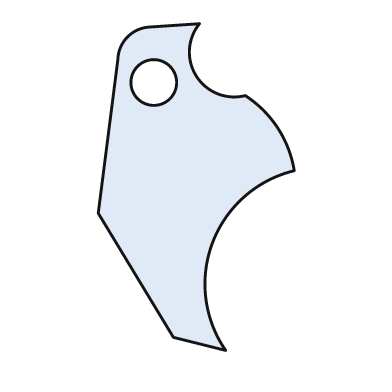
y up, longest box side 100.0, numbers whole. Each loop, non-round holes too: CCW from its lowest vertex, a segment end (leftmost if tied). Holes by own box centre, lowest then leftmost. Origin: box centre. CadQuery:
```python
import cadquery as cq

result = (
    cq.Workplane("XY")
    .moveTo(9.0, -50.0)
    .threePointArc((5.0, -17.0), (30.0, 5.0))
    .threePointArc((25.0, 18.0), (15.0, 28.0))
    .threePointArc((0.0, 34.0), (1.0, 50.0))
    .lineTo(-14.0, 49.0)
    .threePointArc((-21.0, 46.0), (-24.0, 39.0))
    .lineTo(-30.0, -8.0)
    .lineTo(-7.0, -46.0)
    .close()
    .moveTo(-13.0, 32.0)
    .circle(7.0)
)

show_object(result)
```